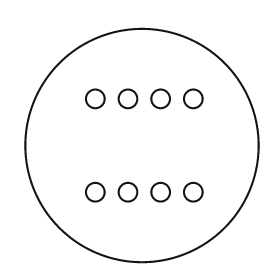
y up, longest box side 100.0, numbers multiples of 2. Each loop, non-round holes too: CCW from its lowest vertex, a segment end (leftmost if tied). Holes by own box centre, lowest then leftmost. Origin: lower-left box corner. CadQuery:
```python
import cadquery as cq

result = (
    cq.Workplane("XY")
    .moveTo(50.0, 50.0)
    .circle(50.0)
    .moveTo(30.0, 30.0)
    .circle(4.0)
    .moveTo(44.0, 30.0)
    .circle(4.0)
    .moveTo(58.0, 30.0)
    .circle(4.0)
    .moveTo(72.0, 30.0)
    .circle(4.0)
    .moveTo(30.0, 70.0)
    .circle(4.0)
    .moveTo(44.0, 70.0)
    .circle(4.0)
    .moveTo(58.0, 70.0)
    .circle(4.0)
    .moveTo(72.0, 70.0)
    .circle(4.0)
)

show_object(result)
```